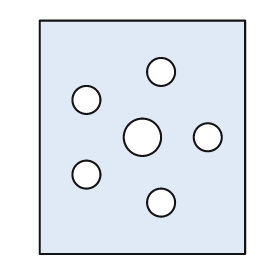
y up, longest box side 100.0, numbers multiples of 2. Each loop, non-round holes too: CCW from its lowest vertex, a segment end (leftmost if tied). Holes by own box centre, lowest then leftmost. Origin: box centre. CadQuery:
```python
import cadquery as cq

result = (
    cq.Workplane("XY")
    .moveTo(-44.0, -50.0)
    .lineTo(44.0, -50.0)
    .lineTo(44.0, 50.0)
    .lineTo(-44.0, 50.0)
    .close()
    .moveTo(8.0, -28.0)
    .circle(6.0)
    .moveTo(-24.0, -16.0)
    .circle(6.0)
    .moveTo(0.0, 0.0)
    .circle(8.0)
    .moveTo(28.0, 0.0)
    .circle(6.0)
    .moveTo(-24.0, 16.0)
    .circle(6.0)
    .moveTo(8.0, 28.0)
    .circle(6.0)
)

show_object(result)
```